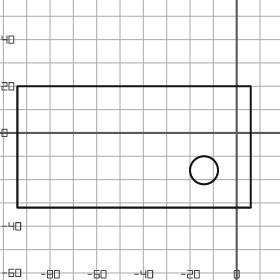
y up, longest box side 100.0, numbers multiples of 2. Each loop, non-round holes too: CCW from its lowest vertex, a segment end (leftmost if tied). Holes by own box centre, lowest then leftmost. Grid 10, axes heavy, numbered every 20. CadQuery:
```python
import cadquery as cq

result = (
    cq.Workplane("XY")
    .moveTo(-94.0, -32.0)
    .lineTo(6.0, -32.0)
    .lineTo(6.0, 20.0)
    .lineTo(-94.0, 20.0)
    .close()
    .moveTo(-14.0, -16.0)
    .circle(6.0)
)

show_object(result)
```